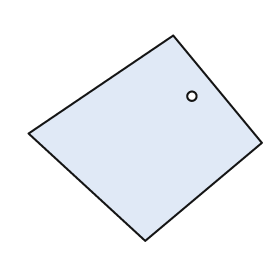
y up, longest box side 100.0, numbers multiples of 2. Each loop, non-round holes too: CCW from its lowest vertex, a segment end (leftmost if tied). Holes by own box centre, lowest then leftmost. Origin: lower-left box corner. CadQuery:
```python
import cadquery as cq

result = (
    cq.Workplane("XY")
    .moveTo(50.0, 0.0)
    .lineTo(100.0, 42.0)
    .lineTo(62.0, 88.0)
    .lineTo(0.0, 46.0)
    .close()
    .moveTo(70.0, 62.0)
    .circle(2.0)
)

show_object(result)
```